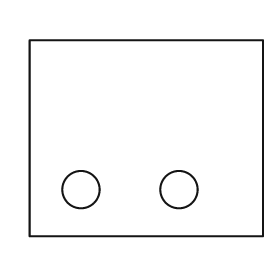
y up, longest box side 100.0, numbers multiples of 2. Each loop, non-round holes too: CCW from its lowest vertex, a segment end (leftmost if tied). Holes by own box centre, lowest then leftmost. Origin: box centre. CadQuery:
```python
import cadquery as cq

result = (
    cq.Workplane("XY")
    .moveTo(-50.0, -42.0)
    .lineTo(50.0, -42.0)
    .lineTo(50.0, 42.0)
    .lineTo(-50.0, 42.0)
    .close()
    .moveTo(-28.0, -22.0)
    .circle(8.0)
    .moveTo(14.0, -22.0)
    .circle(8.0)
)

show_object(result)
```